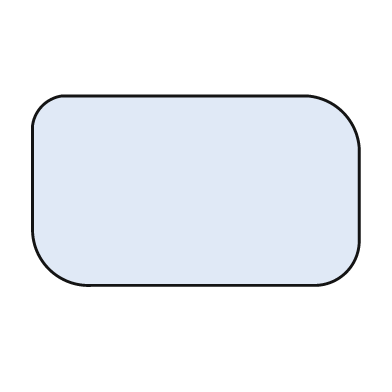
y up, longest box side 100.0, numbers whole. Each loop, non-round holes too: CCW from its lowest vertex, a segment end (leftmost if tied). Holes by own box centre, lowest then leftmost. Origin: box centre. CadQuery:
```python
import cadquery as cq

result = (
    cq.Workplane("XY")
    .moveTo(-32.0, -29.0)
    .lineTo(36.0, -29.0)
    .threePointArc((46.0, -25.0), (50.0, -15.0))
    .lineTo(50.0, 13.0)
    .threePointArc((45.0, 24.0), (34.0, 29.0))
    .lineTo(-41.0, 29.0)
    .threePointArc((-47.0, 26.0), (-50.0, 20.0))
    .lineTo(-50.0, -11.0)
    .threePointArc((-45.0, -24.0), (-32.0, -29.0))
    .close()
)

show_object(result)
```